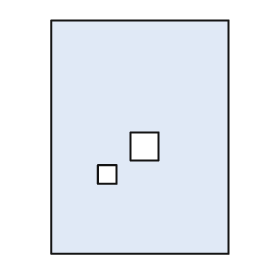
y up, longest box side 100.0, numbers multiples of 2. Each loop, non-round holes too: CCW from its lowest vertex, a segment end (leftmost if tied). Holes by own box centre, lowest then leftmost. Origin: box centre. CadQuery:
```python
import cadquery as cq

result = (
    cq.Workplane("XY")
    .moveTo(-38.0, -50.0)
    .lineTo(38.0, -50.0)
    .lineTo(38.0, 50.0)
    .lineTo(-38.0, 50.0)
    .close()
    .moveTo(-18.0, -20.0)
    .lineTo(-10.0, -20.0)
    .lineTo(-10.0, -12.0)
    .lineTo(-18.0, -12.0)
    .close()
    .moveTo(-4.0, -10.0)
    .lineTo(8.0, -10.0)
    .lineTo(8.0, 2.0)
    .lineTo(-4.0, 2.0)
    .close()
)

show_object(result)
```